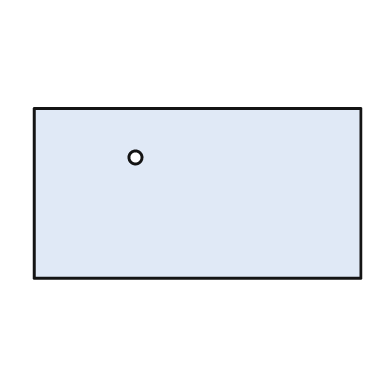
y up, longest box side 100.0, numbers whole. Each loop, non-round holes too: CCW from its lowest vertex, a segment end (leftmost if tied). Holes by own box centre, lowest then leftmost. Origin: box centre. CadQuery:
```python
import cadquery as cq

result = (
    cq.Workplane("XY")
    .moveTo(-50.0, -26.0)
    .lineTo(50.0, -26.0)
    .lineTo(50.0, 26.0)
    .lineTo(-50.0, 26.0)
    .close()
    .moveTo(-19.0, 11.0)
    .circle(2.0)
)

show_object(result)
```